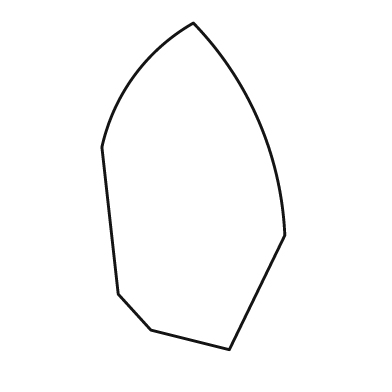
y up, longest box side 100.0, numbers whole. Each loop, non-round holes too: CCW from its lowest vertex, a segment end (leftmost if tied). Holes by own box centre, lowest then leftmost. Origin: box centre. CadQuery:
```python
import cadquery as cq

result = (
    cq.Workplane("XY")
    .moveTo(11.0, -50.0)
    .lineTo(28.0, -15.0)
    .threePointArc((20.0, 20.0), (0.0, 50.0))
    .threePointArc((-18.0, 34.0), (-28.0, 12.0))
    .lineTo(-23.0, -33.0)
    .lineTo(-13.0, -44.0)
    .close()
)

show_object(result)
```